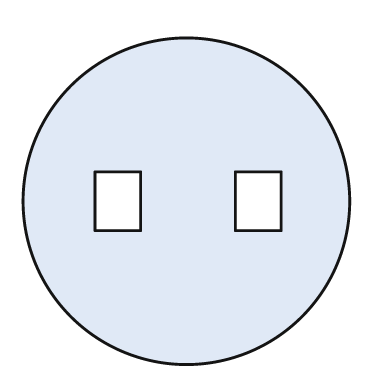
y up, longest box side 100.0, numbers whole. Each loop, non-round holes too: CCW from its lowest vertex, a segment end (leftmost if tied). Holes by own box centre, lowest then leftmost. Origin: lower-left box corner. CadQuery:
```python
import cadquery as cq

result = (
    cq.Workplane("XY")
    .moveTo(50.0, 50.0)
    .circle(50.0)
    .moveTo(22.0, 41.0)
    .lineTo(36.0, 41.0)
    .lineTo(36.0, 59.0)
    .lineTo(22.0, 59.0)
    .close()
    .moveTo(65.0, 41.0)
    .lineTo(79.0, 41.0)
    .lineTo(79.0, 59.0)
    .lineTo(65.0, 59.0)
    .close()
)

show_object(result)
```